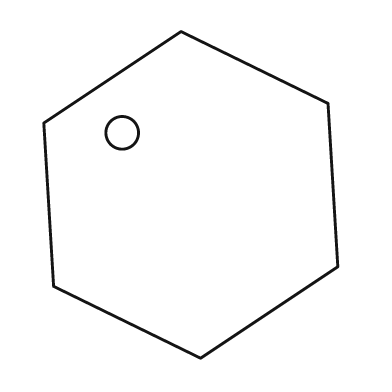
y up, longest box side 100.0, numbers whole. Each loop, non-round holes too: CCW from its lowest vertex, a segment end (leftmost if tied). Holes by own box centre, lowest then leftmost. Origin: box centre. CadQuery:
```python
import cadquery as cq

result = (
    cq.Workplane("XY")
    .moveTo(3.0, -50.0)
    .lineTo(45.0, -22.0)
    .lineTo(42.0, 28.0)
    .lineTo(-3.0, 50.0)
    .lineTo(-45.0, 22.0)
    .lineTo(-42.0, -28.0)
    .close()
    .moveTo(-21.0, 19.0)
    .circle(5.0)
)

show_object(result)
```